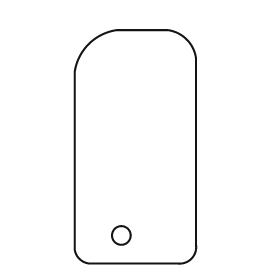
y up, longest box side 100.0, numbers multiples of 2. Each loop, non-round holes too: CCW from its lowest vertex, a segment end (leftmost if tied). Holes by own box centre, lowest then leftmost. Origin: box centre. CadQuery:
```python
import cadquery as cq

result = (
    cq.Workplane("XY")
    .moveTo(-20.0, -50.0)
    .lineTo(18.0, -50.0)
    .threePointArc((24.0, -48.0), (26.0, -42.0))
    .lineTo(26.0, 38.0)
    .threePointArc((22.0, 46.0), (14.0, 50.0))
    .lineTo(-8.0, 50.0)
    .threePointArc((-20.0, 44.0), (-26.0, 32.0))
    .lineTo(-26.0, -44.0)
    .threePointArc((-24.0, -48.0), (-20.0, -50.0))
    .close()
    .moveTo(-6.0, -38.0)
    .circle(4.0)
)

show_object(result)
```